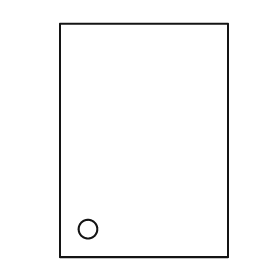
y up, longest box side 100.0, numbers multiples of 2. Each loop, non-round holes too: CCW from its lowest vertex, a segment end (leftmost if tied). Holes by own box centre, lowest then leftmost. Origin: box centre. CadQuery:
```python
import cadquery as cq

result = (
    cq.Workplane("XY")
    .moveTo(-36.0, -50.0)
    .lineTo(36.0, -50.0)
    .lineTo(36.0, 50.0)
    .lineTo(-36.0, 50.0)
    .close()
    .moveTo(-24.0, -38.0)
    .circle(4.0)
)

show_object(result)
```